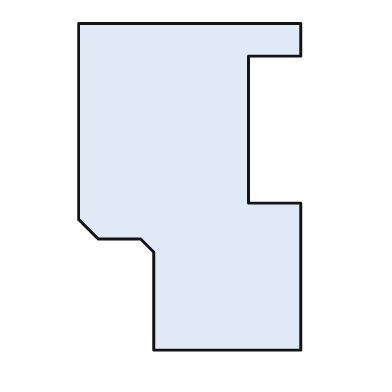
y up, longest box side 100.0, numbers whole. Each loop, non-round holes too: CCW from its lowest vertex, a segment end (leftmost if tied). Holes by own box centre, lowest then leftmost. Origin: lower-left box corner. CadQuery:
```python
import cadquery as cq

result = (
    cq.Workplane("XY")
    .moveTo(23.0, 0.0)
    .lineTo(68.0, 0.0)
    .lineTo(68.0, 45.0)
    .lineTo(52.0, 45.0)
    .lineTo(52.0, 90.0)
    .lineTo(68.0, 90.0)
    .lineTo(68.0, 100.0)
    .lineTo(0.0, 100.0)
    .lineTo(0.0, 40.0)
    .lineTo(6.0, 34.0)
    .lineTo(19.0, 34.0)
    .lineTo(23.0, 30.0)
    .close()
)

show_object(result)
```